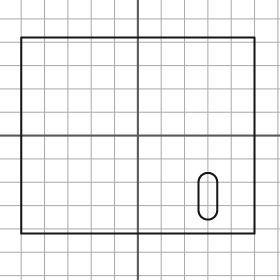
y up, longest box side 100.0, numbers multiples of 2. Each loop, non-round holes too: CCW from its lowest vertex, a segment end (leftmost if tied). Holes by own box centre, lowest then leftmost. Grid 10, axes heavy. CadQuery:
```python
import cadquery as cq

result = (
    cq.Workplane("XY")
    .moveTo(-50.0, -42.0)
    .lineTo(50.0, -42.0)
    .lineTo(50.0, 42.0)
    .lineTo(-50.0, 42.0)
    .close()
    .moveTo(26.0, -32.0)
    .threePointArc((30.0, -36.0), (34.0, -32.0))
    .lineTo(34.0, -20.0)
    .threePointArc((30.0, -16.0), (26.0, -20.0))
    .close()
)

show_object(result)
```